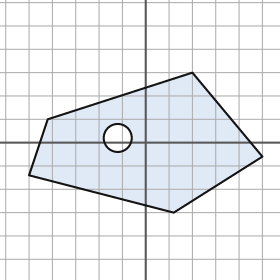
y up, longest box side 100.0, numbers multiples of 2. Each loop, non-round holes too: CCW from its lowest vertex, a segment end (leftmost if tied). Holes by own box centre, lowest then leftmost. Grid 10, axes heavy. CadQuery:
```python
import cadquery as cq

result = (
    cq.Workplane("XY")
    .moveTo(12.0, -30.0)
    .lineTo(50.0, -6.0)
    .lineTo(20.0, 30.0)
    .lineTo(-42.0, 10.0)
    .lineTo(-50.0, -14.0)
    .close()
    .moveTo(-12.0, 2.0)
    .circle(6.0)
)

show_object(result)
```